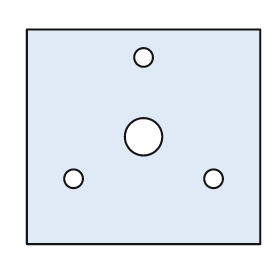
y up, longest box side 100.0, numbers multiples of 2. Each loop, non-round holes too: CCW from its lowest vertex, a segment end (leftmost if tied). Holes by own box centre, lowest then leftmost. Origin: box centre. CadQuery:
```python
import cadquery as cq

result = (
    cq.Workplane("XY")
    .moveTo(-50.0, -46.0)
    .lineTo(50.0, -46.0)
    .lineTo(50.0, 46.0)
    .lineTo(-50.0, 46.0)
    .close()
    .moveTo(-30.0, -18.0)
    .circle(4.0)
    .moveTo(30.0, -18.0)
    .circle(4.0)
    .moveTo(0.0, 0.0)
    .circle(8.0)
    .moveTo(0.0, 34.0)
    .circle(4.0)
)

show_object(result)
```